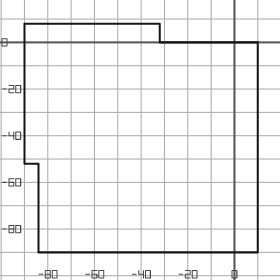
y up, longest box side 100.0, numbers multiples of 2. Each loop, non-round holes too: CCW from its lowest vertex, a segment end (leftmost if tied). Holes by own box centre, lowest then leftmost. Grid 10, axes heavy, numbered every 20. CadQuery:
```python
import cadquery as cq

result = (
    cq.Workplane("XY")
    .moveTo(-84.0, -90.0)
    .lineTo(10.0, -90.0)
    .lineTo(10.0, 0.0)
    .lineTo(-32.0, 0.0)
    .lineTo(-32.0, 8.0)
    .lineTo(-90.0, 8.0)
    .lineTo(-90.0, -52.0)
    .lineTo(-84.0, -52.0)
    .close()
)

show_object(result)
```